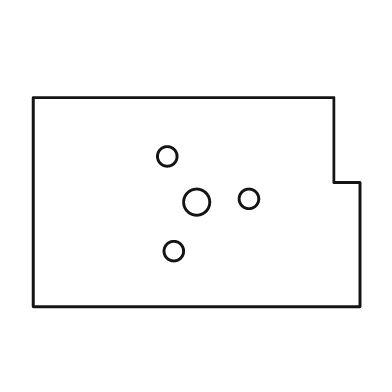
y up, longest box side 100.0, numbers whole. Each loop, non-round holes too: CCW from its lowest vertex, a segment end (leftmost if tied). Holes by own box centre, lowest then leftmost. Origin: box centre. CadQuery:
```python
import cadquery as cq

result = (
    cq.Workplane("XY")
    .moveTo(-50.0, -32.0)
    .lineTo(50.0, -32.0)
    .lineTo(50.0, 6.0)
    .lineTo(42.0, 6.0)
    .lineTo(42.0, 32.0)
    .lineTo(-50.0, 32.0)
    .close()
    .moveTo(-7.0, -15.0)
    .circle(3.0)
    .moveTo(0.0, 0.0)
    .circle(4.0)
    .moveTo(16.0, 1.0)
    .circle(3.0)
    .moveTo(-9.0, 14.0)
    .circle(3.0)
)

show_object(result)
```